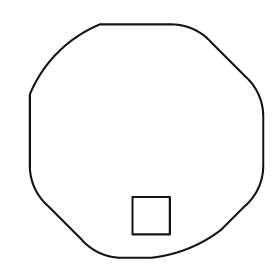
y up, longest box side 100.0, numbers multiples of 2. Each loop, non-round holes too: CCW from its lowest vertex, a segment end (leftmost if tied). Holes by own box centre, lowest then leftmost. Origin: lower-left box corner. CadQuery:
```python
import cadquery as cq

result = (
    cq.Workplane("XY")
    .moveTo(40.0, 0.0)
    .lineTo(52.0, 0.0)
    .threePointArc((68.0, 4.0), (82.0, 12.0))
    .lineTo(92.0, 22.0)
    .threePointArc((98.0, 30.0), (100.0, 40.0))
    .lineTo(100.0, 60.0)
    .threePointArc((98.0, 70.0), (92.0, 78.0))
    .lineTo(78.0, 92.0)
    .threePointArc((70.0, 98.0), (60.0, 100.0))
    .lineTo(30.0, 100.0)
    .threePointArc((12.0, 88.0), (0.0, 70.0))
    .lineTo(0.0, 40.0)
    .threePointArc((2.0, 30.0), (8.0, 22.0))
    .lineTo(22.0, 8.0)
    .threePointArc((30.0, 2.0), (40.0, 0.0))
    .close()
    .moveTo(44.0, 10.0)
    .lineTo(60.0, 10.0)
    .lineTo(60.0, 26.0)
    .lineTo(44.0, 26.0)
    .close()
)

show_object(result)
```